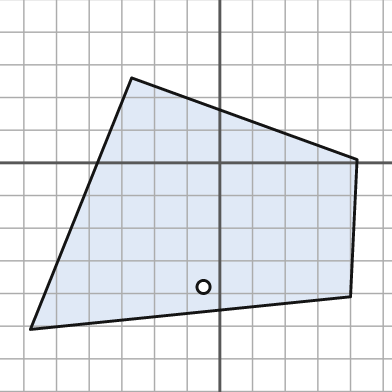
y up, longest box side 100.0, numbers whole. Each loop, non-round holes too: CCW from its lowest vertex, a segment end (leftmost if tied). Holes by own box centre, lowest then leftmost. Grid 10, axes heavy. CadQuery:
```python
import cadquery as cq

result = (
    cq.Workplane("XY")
    .moveTo(-58.0, -51.0)
    .lineTo(40.0, -41.0)
    .lineTo(42.0, 1.0)
    .lineTo(-27.0, 26.0)
    .close()
    .moveTo(-5.0, -38.0)
    .circle(2.0)
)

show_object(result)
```